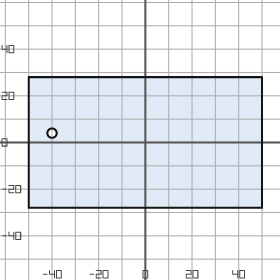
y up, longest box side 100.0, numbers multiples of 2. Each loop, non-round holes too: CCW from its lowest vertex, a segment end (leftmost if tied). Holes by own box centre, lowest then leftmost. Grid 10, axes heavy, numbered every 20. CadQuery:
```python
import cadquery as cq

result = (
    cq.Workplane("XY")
    .moveTo(-50.0, -28.0)
    .lineTo(50.0, -28.0)
    .lineTo(50.0, 28.0)
    .lineTo(-50.0, 28.0)
    .close()
    .moveTo(-40.0, 4.0)
    .circle(2.0)
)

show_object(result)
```